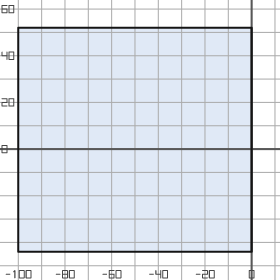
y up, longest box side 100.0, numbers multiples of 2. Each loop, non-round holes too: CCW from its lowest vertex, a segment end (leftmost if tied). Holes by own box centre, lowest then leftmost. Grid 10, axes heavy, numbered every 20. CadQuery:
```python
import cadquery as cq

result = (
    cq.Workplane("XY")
    .moveTo(-100.0, -44.0)
    .lineTo(0.0, -44.0)
    .lineTo(0.0, 52.0)
    .lineTo(-100.0, 52.0)
    .close()
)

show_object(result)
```